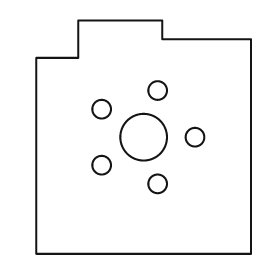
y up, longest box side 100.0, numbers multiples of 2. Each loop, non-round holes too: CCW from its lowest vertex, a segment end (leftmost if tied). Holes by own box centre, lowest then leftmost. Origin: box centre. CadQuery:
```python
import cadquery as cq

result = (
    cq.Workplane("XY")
    .moveTo(-46.0, -50.0)
    .lineTo(46.0, -50.0)
    .lineTo(46.0, 42.0)
    .lineTo(8.0, 42.0)
    .lineTo(8.0, 50.0)
    .lineTo(-28.0, 50.0)
    .lineTo(-28.0, 34.0)
    .lineTo(-46.0, 34.0)
    .close()
    .moveTo(6.0, -20.0)
    .circle(4.0)
    .moveTo(-18.0, -12.0)
    .circle(4.0)
    .moveTo(0.0, 0.0)
    .circle(10.0)
    .moveTo(22.0, 0.0)
    .circle(4.0)
    .moveTo(-18.0, 12.0)
    .circle(4.0)
    .moveTo(6.0, 20.0)
    .circle(4.0)
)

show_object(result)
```